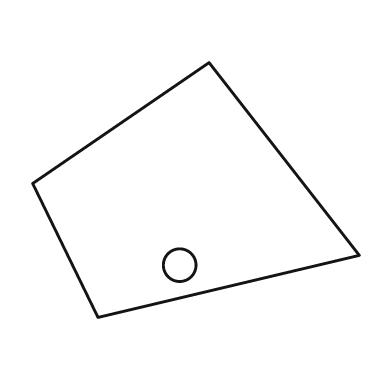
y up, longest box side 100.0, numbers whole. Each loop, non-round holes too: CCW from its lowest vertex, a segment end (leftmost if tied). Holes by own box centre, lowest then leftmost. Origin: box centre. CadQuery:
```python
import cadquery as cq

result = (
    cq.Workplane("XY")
    .moveTo(-30.0, -39.0)
    .lineTo(50.0, -20.0)
    .lineTo(4.0, 39.0)
    .lineTo(-50.0, 2.0)
    .close()
    .moveTo(-5.0, -23.0)
    .circle(5.0)
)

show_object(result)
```